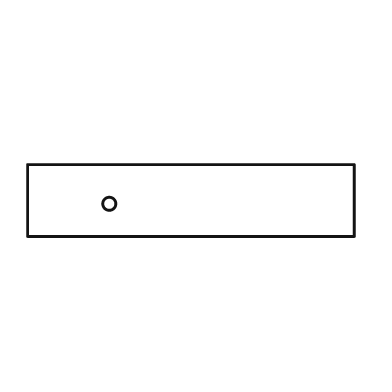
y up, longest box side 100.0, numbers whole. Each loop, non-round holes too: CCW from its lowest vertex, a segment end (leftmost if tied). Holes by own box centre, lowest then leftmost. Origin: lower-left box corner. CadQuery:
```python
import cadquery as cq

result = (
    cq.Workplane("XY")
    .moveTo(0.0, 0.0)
    .lineTo(100.0, 0.0)
    .lineTo(100.0, 22.0)
    .lineTo(0.0, 22.0)
    .close()
    .moveTo(25.0, 10.0)
    .circle(2.0)
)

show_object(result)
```